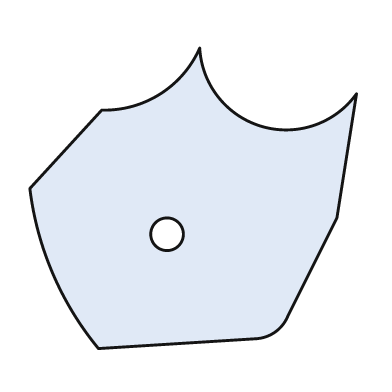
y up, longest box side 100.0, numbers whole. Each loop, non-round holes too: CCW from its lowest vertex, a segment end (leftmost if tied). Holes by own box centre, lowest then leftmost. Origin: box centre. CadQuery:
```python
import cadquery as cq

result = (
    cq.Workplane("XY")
    .moveTo(-29.0, -46.0)
    .lineTo(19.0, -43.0)
    .threePointArc((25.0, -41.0), (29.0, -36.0))
    .lineTo(44.0, -6.0)
    .lineTo(50.0, 32.0)
    .threePointArc((21.0, 22.0), (2.0, 46.0))
    .threePointArc((-10.0, 32.0), (-28.0, 27.0))
    .lineTo(-50.0, 3.0)
    .threePointArc((-43.0, -23.0), (-29.0, -46.0))
    .close()
    .moveTo(-8.0, -11.0)
    .circle(5.0)
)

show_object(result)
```